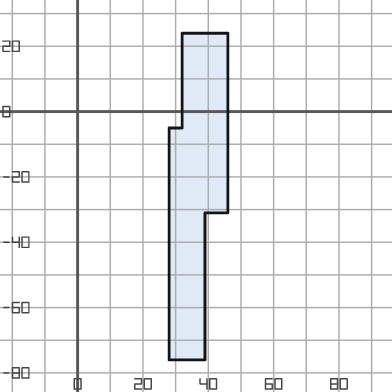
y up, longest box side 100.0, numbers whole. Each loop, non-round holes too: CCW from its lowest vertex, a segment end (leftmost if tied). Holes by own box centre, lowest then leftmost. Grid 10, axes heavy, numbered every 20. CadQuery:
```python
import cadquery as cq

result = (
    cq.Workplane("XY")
    .moveTo(28.0, -76.0)
    .lineTo(39.0, -76.0)
    .lineTo(39.0, -31.0)
    .lineTo(46.0, -31.0)
    .lineTo(46.0, 24.0)
    .lineTo(32.0, 24.0)
    .lineTo(32.0, -5.0)
    .lineTo(28.0, -5.0)
    .close()
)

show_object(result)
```